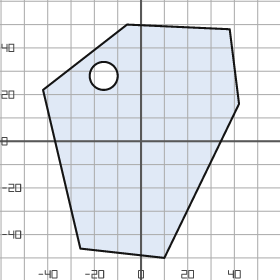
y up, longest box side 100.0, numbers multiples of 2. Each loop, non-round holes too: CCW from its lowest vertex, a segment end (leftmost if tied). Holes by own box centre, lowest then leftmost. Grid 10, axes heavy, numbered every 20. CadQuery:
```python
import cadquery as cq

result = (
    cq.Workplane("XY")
    .moveTo(10.0, -50.0)
    .lineTo(42.0, 16.0)
    .lineTo(38.0, 48.0)
    .lineTo(-6.0, 50.0)
    .lineTo(-42.0, 22.0)
    .lineTo(-26.0, -46.0)
    .close()
    .moveTo(-16.0, 28.0)
    .circle(6.0)
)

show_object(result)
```